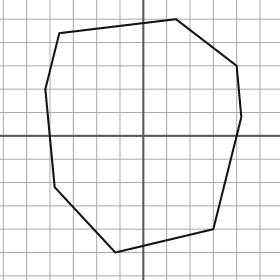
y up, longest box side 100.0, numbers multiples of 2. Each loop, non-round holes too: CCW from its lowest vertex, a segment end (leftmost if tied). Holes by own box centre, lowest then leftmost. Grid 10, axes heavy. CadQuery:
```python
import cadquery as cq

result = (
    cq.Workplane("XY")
    .moveTo(-12.0, -50.0)
    .lineTo(30.0, -40.0)
    .lineTo(42.0, 8.0)
    .lineTo(40.0, 30.0)
    .lineTo(14.0, 50.0)
    .lineTo(-36.0, 44.0)
    .lineTo(-42.0, 20.0)
    .lineTo(-38.0, -22.0)
    .close()
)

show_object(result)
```